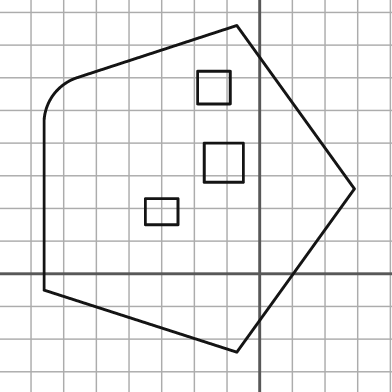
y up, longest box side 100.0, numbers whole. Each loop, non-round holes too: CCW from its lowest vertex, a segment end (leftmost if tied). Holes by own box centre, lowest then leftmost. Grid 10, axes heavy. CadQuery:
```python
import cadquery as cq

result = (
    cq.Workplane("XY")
    .moveTo(-7.0, -24.0)
    .lineTo(29.0, 26.0)
    .lineTo(-7.0, 76.0)
    .lineTo(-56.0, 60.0)
    .threePointArc((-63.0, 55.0), (-66.0, 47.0))
    .lineTo(-66.0, -5.0)
    .close()
    .moveTo(-35.0, 15.0)
    .lineTo(-25.0, 15.0)
    .lineTo(-25.0, 23.0)
    .lineTo(-35.0, 23.0)
    .close()
    .moveTo(-17.0, 28.0)
    .lineTo(-5.0, 28.0)
    .lineTo(-5.0, 40.0)
    .lineTo(-17.0, 40.0)
    .close()
    .moveTo(-19.0, 52.0)
    .lineTo(-9.0, 52.0)
    .lineTo(-9.0, 62.0)
    .lineTo(-19.0, 62.0)
    .close()
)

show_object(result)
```